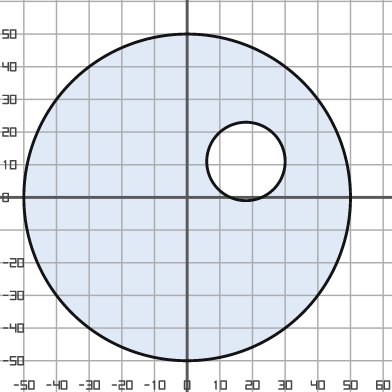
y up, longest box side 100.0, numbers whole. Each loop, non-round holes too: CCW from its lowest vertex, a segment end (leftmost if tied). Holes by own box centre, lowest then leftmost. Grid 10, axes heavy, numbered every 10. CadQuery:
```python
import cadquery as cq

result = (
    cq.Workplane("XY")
    .moveTo(0.0, 0.0)
    .circle(50.0)
    .moveTo(18.0, 11.0)
    .circle(12.0)
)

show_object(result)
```